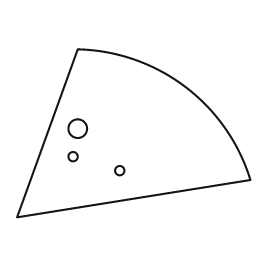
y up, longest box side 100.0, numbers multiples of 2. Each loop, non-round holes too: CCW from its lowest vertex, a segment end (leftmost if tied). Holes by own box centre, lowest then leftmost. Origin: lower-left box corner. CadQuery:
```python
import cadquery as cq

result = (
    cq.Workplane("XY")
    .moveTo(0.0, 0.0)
    .lineTo(100.0, 16.0)
    .threePointArc((72.0, 56.0), (26.0, 72.0))
    .close()
    .moveTo(44.0, 20.0)
    .circle(2.0)
    .moveTo(24.0, 26.0)
    .circle(2.0)
    .moveTo(26.0, 38.0)
    .circle(4.0)
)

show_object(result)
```